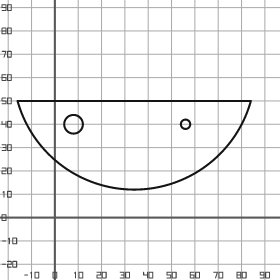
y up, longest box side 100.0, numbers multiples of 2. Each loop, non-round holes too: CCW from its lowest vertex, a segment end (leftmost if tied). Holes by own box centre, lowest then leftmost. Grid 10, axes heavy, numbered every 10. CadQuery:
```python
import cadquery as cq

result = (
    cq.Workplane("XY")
    .moveTo(-16.0, 50.0)
    .threePointArc((34.0, 12.0), (84.0, 50.0))
    .close()
    .moveTo(8.0, 40.0)
    .circle(4.0)
    .moveTo(56.0, 40.0)
    .circle(2.0)
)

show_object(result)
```